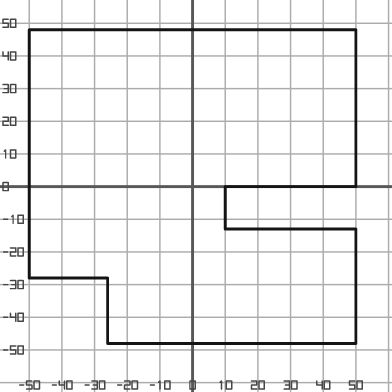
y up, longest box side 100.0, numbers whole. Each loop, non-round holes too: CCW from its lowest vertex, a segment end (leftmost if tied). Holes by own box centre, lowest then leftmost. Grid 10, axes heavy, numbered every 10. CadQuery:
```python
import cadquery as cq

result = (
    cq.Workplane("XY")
    .moveTo(-26.0, -48.0)
    .lineTo(50.0, -48.0)
    .lineTo(50.0, -13.0)
    .lineTo(10.0, -13.0)
    .lineTo(10.0, 0.0)
    .lineTo(50.0, 0.0)
    .lineTo(50.0, 48.0)
    .lineTo(-50.0, 48.0)
    .lineTo(-50.0, -28.0)
    .lineTo(-26.0, -28.0)
    .close()
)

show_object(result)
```